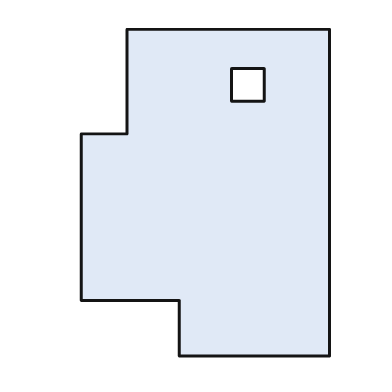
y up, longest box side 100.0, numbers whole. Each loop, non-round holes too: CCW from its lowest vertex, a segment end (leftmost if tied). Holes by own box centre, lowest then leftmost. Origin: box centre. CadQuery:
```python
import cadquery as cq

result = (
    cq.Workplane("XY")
    .moveTo(-8.0, -50.0)
    .lineTo(38.0, -50.0)
    .lineTo(38.0, 50.0)
    .lineTo(-24.0, 50.0)
    .lineTo(-24.0, 18.0)
    .lineTo(-38.0, 18.0)
    .lineTo(-38.0, -33.0)
    .lineTo(-8.0, -33.0)
    .close()
    .moveTo(8.0, 28.0)
    .lineTo(18.0, 28.0)
    .lineTo(18.0, 38.0)
    .lineTo(8.0, 38.0)
    .close()
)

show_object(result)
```